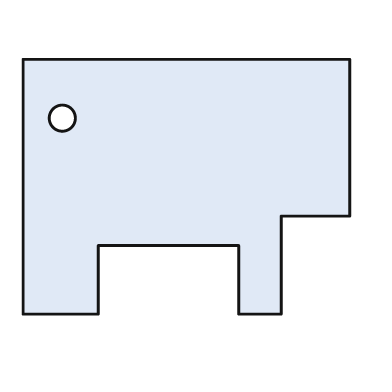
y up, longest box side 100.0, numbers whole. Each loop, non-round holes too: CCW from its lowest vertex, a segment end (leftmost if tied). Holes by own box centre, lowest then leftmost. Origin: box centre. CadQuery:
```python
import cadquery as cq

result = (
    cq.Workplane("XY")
    .moveTo(-50.0, -39.0)
    .lineTo(-27.0, -39.0)
    .lineTo(-27.0, -18.0)
    .lineTo(16.0, -18.0)
    .lineTo(16.0, -39.0)
    .lineTo(29.0, -39.0)
    .lineTo(29.0, -9.0)
    .lineTo(50.0, -9.0)
    .lineTo(50.0, 39.0)
    .lineTo(-50.0, 39.0)
    .close()
    .moveTo(-38.0, 21.0)
    .circle(4.0)
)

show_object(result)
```